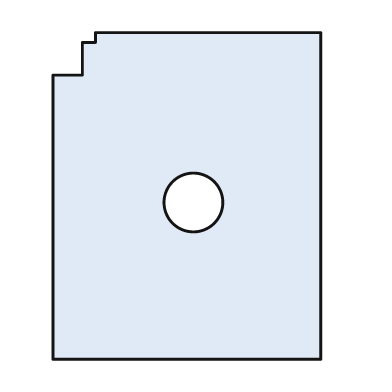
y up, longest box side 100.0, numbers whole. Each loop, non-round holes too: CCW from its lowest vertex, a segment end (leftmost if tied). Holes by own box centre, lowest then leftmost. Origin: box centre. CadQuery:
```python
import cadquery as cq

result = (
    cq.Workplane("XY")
    .moveTo(-41.0, -50.0)
    .lineTo(41.0, -50.0)
    .lineTo(41.0, 50.0)
    .lineTo(-28.0, 50.0)
    .lineTo(-28.0, 47.0)
    .lineTo(-32.0, 47.0)
    .lineTo(-32.0, 37.0)
    .lineTo(-41.0, 37.0)
    .close()
    .moveTo(2.0, -2.0)
    .circle(9.0)
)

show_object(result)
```